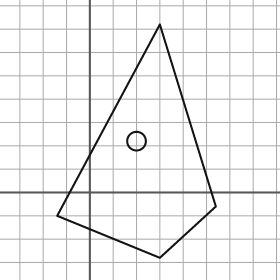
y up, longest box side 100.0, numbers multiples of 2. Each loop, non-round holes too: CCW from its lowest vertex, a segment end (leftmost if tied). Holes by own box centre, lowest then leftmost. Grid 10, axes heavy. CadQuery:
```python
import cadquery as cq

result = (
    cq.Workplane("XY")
    .moveTo(30.0, -28.0)
    .lineTo(54.0, -6.0)
    .lineTo(30.0, 72.0)
    .lineTo(-14.0, -10.0)
    .close()
    .moveTo(20.0, 22.0)
    .circle(4.0)
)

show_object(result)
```